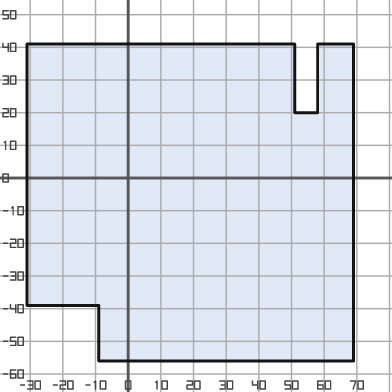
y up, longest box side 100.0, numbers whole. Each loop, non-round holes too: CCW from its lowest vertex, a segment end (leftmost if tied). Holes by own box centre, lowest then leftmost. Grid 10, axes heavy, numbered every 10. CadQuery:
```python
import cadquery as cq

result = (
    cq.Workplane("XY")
    .moveTo(-9.0, -56.0)
    .lineTo(69.0, -56.0)
    .lineTo(69.0, 41.0)
    .lineTo(58.0, 41.0)
    .lineTo(58.0, 20.0)
    .lineTo(51.0, 20.0)
    .lineTo(51.0, 41.0)
    .lineTo(-31.0, 41.0)
    .lineTo(-31.0, -39.0)
    .lineTo(-9.0, -39.0)
    .close()
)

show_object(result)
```